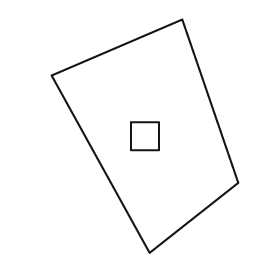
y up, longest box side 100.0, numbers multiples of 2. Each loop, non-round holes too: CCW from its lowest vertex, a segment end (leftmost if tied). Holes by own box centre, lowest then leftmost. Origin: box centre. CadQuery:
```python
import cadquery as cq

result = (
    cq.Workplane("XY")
    .moveTo(2.0, -50.0)
    .lineTo(40.0, -20.0)
    .lineTo(16.0, 50.0)
    .lineTo(-40.0, 26.0)
    .close()
    .moveTo(-6.0, -6.0)
    .lineTo(6.0, -6.0)
    .lineTo(6.0, 6.0)
    .lineTo(-6.0, 6.0)
    .close()
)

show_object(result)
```